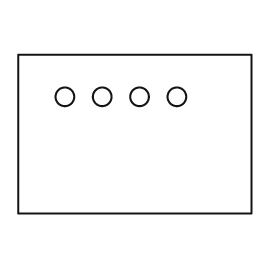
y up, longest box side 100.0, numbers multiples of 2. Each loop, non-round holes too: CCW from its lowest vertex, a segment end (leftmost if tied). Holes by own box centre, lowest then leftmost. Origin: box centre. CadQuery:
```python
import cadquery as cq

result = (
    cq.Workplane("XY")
    .moveTo(-50.0, -34.0)
    .lineTo(50.0, -34.0)
    .lineTo(50.0, 34.0)
    .lineTo(-50.0, 34.0)
    .close()
    .moveTo(-30.0, 16.0)
    .circle(4.0)
    .moveTo(-14.0, 16.0)
    .circle(4.0)
    .moveTo(2.0, 16.0)
    .circle(4.0)
    .moveTo(18.0, 16.0)
    .circle(4.0)
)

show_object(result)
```